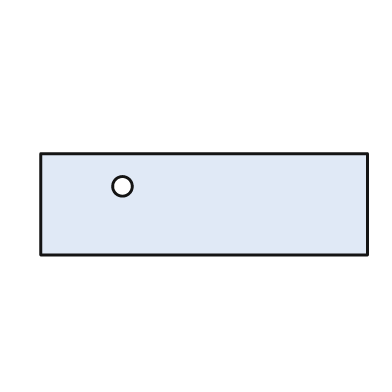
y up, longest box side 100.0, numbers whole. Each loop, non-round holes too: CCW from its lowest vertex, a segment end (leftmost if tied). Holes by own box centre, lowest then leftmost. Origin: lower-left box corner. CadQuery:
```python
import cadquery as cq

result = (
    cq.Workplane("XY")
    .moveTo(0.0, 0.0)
    .lineTo(100.0, 0.0)
    .lineTo(100.0, 31.0)
    .lineTo(0.0, 31.0)
    .close()
    .moveTo(25.0, 21.0)
    .circle(3.0)
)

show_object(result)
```